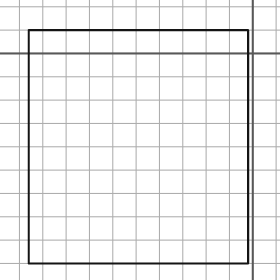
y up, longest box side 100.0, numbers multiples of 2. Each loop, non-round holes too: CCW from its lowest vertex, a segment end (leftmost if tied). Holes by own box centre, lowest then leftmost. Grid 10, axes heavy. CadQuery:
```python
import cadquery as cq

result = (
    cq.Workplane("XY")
    .moveTo(-96.0, -90.0)
    .lineTo(-2.0, -90.0)
    .lineTo(-2.0, 10.0)
    .lineTo(-96.0, 10.0)
    .close()
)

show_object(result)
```